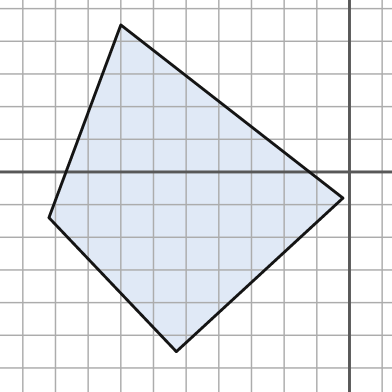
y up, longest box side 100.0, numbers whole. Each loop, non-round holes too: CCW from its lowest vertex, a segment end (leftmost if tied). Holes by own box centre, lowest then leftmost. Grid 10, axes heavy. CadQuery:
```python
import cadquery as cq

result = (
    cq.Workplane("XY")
    .moveTo(-53.0, -55.0)
    .lineTo(-2.0, -8.0)
    .lineTo(-70.0, 45.0)
    .lineTo(-92.0, -14.0)
    .close()
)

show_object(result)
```